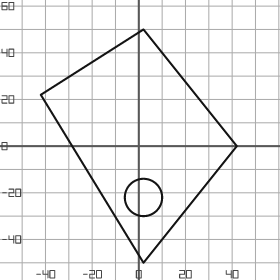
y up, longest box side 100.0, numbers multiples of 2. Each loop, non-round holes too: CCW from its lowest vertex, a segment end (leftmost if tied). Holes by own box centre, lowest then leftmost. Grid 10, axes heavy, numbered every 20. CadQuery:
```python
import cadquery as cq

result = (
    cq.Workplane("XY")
    .moveTo(2.0, -50.0)
    .lineTo(42.0, 0.0)
    .lineTo(2.0, 50.0)
    .lineTo(-42.0, 22.0)
    .close()
    .moveTo(2.0, -22.0)
    .circle(8.0)
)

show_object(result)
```